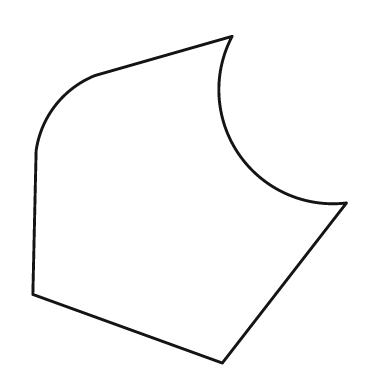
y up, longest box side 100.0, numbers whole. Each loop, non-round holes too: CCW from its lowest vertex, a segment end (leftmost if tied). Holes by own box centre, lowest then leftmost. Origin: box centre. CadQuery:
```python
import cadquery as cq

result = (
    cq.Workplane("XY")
    .moveTo(10.0, -50.0)
    .lineTo(48.0, -1.0)
    .threePointArc((15.0, 14.0), (13.0, 50.0))
    .lineTo(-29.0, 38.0)
    .threePointArc((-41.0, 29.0), (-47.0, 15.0))
    .lineTo(-48.0, -29.0)
    .close()
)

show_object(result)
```